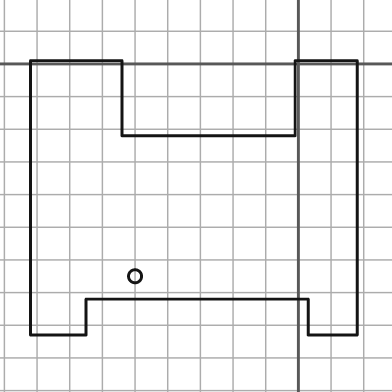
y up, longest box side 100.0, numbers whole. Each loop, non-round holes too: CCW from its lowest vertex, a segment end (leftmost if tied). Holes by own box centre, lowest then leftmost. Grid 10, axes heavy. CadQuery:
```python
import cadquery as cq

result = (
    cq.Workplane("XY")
    .moveTo(-82.0, -83.0)
    .lineTo(-65.0, -83.0)
    .lineTo(-65.0, -72.0)
    .lineTo(3.0, -72.0)
    .lineTo(3.0, -83.0)
    .lineTo(18.0, -83.0)
    .lineTo(18.0, 1.0)
    .lineTo(-1.0, 1.0)
    .lineTo(-1.0, -22.0)
    .lineTo(-54.0, -22.0)
    .lineTo(-54.0, 1.0)
    .lineTo(-82.0, 1.0)
    .close()
    .moveTo(-50.0, -65.0)
    .circle(2.0)
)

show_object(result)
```